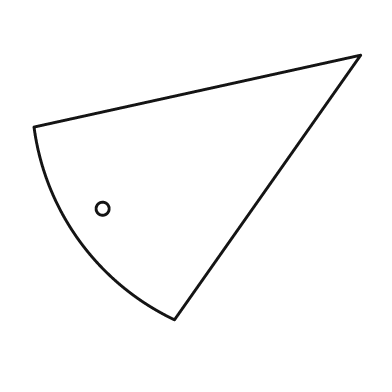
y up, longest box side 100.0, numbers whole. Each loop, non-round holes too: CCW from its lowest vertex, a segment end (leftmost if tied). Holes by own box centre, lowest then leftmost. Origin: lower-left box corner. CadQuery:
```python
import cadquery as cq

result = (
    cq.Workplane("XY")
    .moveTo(43.0, 0.0)
    .lineTo(100.0, 81.0)
    .lineTo(0.0, 59.0)
    .threePointArc((14.0, 24.0), (43.0, 0.0))
    .close()
    .moveTo(21.0, 34.0)
    .circle(2.0)
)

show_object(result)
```